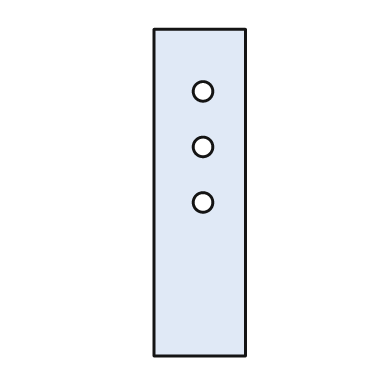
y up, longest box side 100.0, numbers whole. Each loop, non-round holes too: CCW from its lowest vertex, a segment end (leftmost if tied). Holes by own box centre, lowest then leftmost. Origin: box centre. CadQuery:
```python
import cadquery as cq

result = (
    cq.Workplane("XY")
    .moveTo(-14.0, -50.0)
    .lineTo(14.0, -50.0)
    .lineTo(14.0, 50.0)
    .lineTo(-14.0, 50.0)
    .close()
    .moveTo(1.0, -3.0)
    .circle(3.0)
    .moveTo(1.0, 14.0)
    .circle(3.0)
    .moveTo(1.0, 31.0)
    .circle(3.0)
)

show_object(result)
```